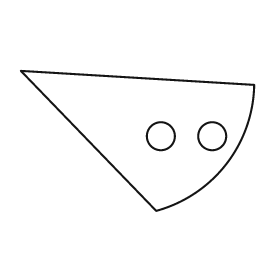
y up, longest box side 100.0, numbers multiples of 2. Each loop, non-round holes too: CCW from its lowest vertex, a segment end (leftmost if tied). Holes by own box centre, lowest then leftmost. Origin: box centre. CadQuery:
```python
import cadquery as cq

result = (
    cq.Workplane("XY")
    .moveTo(8.0, -30.0)
    .threePointArc((38.0, -10.0), (50.0, 24.0))
    .lineTo(-50.0, 30.0)
    .close()
    .moveTo(10.0, 2.0)
    .circle(6.0)
    .moveTo(32.0, 2.0)
    .circle(6.0)
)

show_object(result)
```